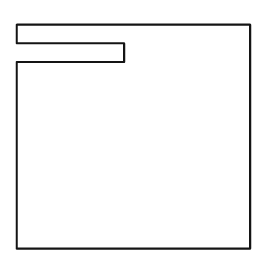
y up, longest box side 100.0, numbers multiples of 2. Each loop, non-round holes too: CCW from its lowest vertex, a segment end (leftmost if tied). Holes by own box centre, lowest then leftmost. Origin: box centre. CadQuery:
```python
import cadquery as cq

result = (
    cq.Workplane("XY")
    .moveTo(-50.0, -48.0)
    .lineTo(50.0, -48.0)
    .lineTo(50.0, 48.0)
    .lineTo(-50.0, 48.0)
    .lineTo(-50.0, 40.0)
    .lineTo(-4.0, 40.0)
    .lineTo(-4.0, 32.0)
    .lineTo(-50.0, 32.0)
    .close()
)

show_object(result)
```